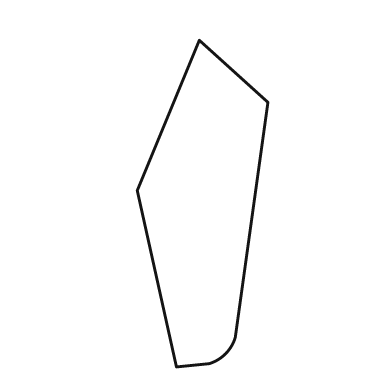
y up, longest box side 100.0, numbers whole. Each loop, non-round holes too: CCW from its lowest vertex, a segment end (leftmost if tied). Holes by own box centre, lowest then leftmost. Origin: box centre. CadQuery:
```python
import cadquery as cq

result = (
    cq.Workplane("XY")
    .moveTo(-8.0, -50.0)
    .lineTo(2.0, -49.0)
    .threePointArc((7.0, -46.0), (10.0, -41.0))
    .lineTo(20.0, 31.0)
    .lineTo(-1.0, 50.0)
    .lineTo(-20.0, 4.0)
    .close()
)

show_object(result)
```